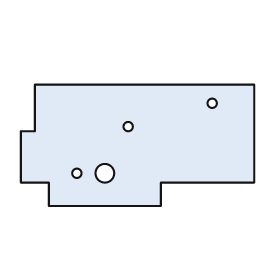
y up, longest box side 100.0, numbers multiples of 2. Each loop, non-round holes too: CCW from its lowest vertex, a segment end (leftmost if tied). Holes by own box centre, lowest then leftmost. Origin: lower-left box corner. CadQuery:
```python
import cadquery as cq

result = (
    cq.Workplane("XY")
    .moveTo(12.0, 0.0)
    .lineTo(60.0, 0.0)
    .lineTo(60.0, 10.0)
    .lineTo(100.0, 10.0)
    .lineTo(100.0, 52.0)
    .lineTo(6.0, 52.0)
    .lineTo(6.0, 32.0)
    .lineTo(0.0, 32.0)
    .lineTo(0.0, 10.0)
    .lineTo(12.0, 10.0)
    .close()
    .moveTo(24.0, 14.0)
    .circle(2.0)
    .moveTo(36.0, 14.0)
    .circle(4.0)
    .moveTo(46.0, 34.0)
    .circle(2.0)
    .moveTo(82.0, 44.0)
    .circle(2.0)
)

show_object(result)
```